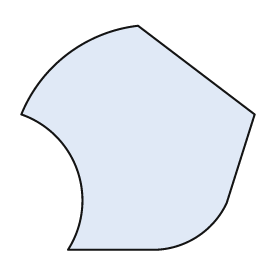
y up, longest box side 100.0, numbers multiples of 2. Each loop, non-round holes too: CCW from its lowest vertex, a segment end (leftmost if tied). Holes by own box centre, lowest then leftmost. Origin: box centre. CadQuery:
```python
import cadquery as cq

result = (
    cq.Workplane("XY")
    .moveTo(-30.0, -48.0)
    .lineTo(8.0, -48.0)
    .threePointArc((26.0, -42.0), (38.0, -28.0))
    .lineTo(50.0, 10.0)
    .lineTo(0.0, 48.0)
    .threePointArc((-30.0, 36.0), (-50.0, 10.0))
    .threePointArc((-26.0, -14.0), (-30.0, -48.0))
    .close()
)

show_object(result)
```